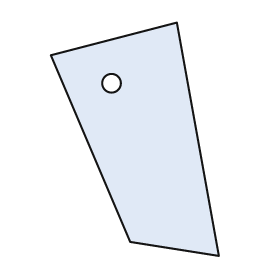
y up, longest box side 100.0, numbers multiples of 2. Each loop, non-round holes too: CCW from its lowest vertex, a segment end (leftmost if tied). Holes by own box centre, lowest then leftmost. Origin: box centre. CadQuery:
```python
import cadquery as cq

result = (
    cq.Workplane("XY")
    .moveTo(36.0, -50.0)
    .lineTo(18.0, 50.0)
    .lineTo(-36.0, 36.0)
    .lineTo(-2.0, -44.0)
    .close()
    .moveTo(-10.0, 24.0)
    .circle(4.0)
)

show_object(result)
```